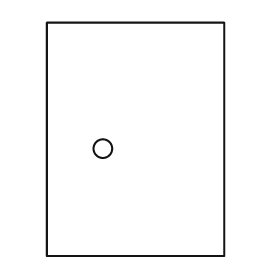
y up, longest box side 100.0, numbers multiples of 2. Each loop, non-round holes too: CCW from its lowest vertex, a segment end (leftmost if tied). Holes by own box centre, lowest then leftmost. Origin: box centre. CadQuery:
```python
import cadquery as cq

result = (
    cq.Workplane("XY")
    .moveTo(-38.0, -50.0)
    .lineTo(38.0, -50.0)
    .lineTo(38.0, 50.0)
    .lineTo(-38.0, 50.0)
    .close()
    .moveTo(-14.0, -4.0)
    .circle(4.0)
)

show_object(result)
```